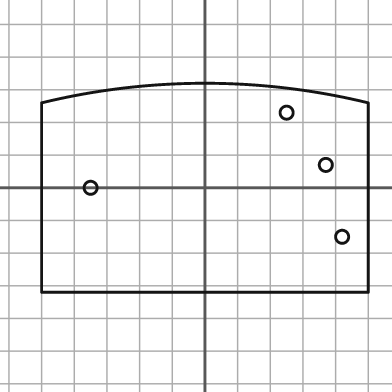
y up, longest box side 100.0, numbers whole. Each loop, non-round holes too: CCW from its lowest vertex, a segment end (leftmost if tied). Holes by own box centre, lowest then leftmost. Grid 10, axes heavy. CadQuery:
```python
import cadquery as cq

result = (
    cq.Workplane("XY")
    .moveTo(-50.0, -32.0)
    .lineTo(50.0, -32.0)
    .lineTo(50.0, 26.0)
    .threePointArc((0.0, 32.0), (-50.0, 26.0))
    .close()
    .moveTo(42.0, -15.0)
    .circle(2.0)
    .moveTo(-35.0, 0.0)
    .circle(2.0)
    .moveTo(37.0, 7.0)
    .circle(2.0)
    .moveTo(25.0, 23.0)
    .circle(2.0)
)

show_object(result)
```